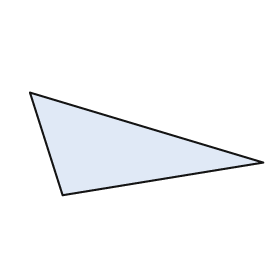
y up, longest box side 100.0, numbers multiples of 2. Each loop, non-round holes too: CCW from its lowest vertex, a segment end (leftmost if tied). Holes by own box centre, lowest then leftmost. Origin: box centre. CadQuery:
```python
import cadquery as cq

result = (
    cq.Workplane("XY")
    .moveTo(-36.0, -22.0)
    .lineTo(50.0, -8.0)
    .lineTo(-50.0, 22.0)
    .close()
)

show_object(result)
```